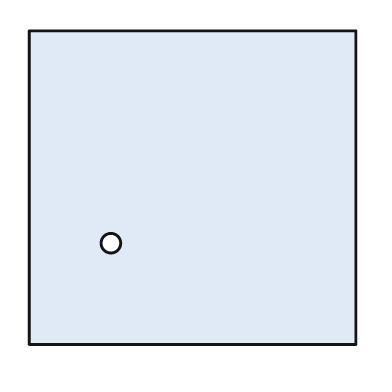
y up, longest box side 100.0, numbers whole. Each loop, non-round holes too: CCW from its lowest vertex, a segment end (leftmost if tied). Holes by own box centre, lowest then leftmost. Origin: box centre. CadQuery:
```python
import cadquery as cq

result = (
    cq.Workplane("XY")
    .moveTo(-50.0, -48.0)
    .lineTo(50.0, -48.0)
    .lineTo(50.0, 48.0)
    .lineTo(-50.0, 48.0)
    .close()
    .moveTo(-25.0, -17.0)
    .circle(3.0)
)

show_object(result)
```